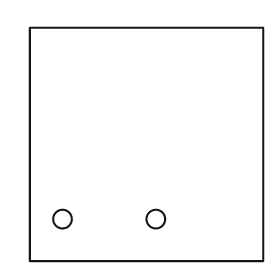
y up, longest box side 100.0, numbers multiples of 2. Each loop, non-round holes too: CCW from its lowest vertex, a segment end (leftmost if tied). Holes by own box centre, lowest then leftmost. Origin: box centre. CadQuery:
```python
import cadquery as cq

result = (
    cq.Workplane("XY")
    .moveTo(-50.0, -50.0)
    .lineTo(50.0, -50.0)
    .lineTo(50.0, 50.0)
    .lineTo(-50.0, 50.0)
    .close()
    .moveTo(-36.0, -32.0)
    .circle(4.0)
    .moveTo(4.0, -32.0)
    .circle(4.0)
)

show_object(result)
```